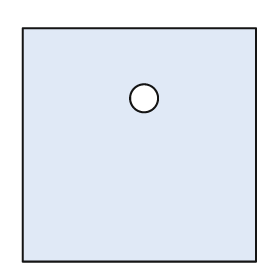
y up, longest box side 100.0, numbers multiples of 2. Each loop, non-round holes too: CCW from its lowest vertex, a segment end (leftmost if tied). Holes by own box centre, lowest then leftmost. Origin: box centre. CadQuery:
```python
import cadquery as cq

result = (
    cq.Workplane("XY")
    .moveTo(-50.0, -50.0)
    .lineTo(50.0, -50.0)
    .lineTo(50.0, 50.0)
    .lineTo(-50.0, 50.0)
    .close()
    .moveTo(2.0, 20.0)
    .circle(6.0)
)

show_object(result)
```